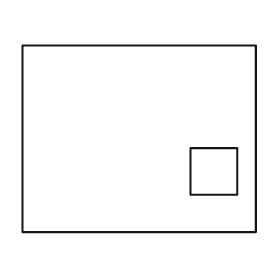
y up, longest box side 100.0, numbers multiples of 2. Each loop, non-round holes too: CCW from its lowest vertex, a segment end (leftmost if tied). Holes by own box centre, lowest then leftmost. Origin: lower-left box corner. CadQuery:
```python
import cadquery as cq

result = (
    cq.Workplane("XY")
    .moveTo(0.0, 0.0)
    .lineTo(100.0, 0.0)
    .lineTo(100.0, 80.0)
    .lineTo(0.0, 80.0)
    .close()
    .moveTo(72.0, 16.0)
    .lineTo(92.0, 16.0)
    .lineTo(92.0, 36.0)
    .lineTo(72.0, 36.0)
    .close()
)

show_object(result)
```